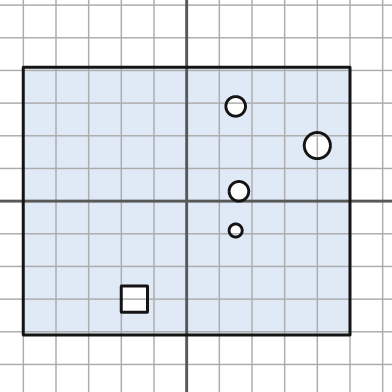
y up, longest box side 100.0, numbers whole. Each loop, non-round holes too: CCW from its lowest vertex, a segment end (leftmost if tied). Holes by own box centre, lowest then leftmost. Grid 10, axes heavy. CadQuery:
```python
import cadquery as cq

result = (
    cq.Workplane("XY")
    .moveTo(-50.0, -41.0)
    .lineTo(50.0, -41.0)
    .lineTo(50.0, 41.0)
    .lineTo(-50.0, 41.0)
    .close()
    .moveTo(-20.0, -34.0)
    .lineTo(-12.0, -34.0)
    .lineTo(-12.0, -26.0)
    .lineTo(-20.0, -26.0)
    .close()
    .moveTo(15.0, -9.0)
    .circle(2.0)
    .moveTo(16.0, 3.0)
    .circle(3.0)
    .moveTo(40.0, 17.0)
    .circle(4.0)
    .moveTo(15.0, 29.0)
    .circle(3.0)
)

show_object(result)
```